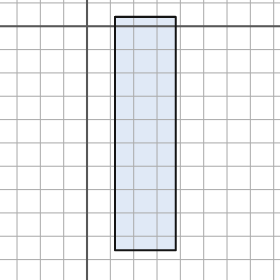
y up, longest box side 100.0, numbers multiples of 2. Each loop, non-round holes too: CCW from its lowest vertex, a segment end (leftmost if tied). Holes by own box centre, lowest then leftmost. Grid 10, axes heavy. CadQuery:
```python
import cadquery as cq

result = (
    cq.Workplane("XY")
    .moveTo(12.0, -96.0)
    .lineTo(38.0, -96.0)
    .lineTo(38.0, 4.0)
    .lineTo(12.0, 4.0)
    .close()
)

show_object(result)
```